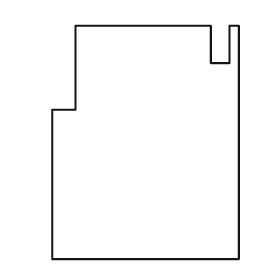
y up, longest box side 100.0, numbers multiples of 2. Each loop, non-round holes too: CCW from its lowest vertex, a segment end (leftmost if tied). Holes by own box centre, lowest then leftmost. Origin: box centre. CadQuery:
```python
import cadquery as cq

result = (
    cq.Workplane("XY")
    .moveTo(-40.0, -50.0)
    .lineTo(40.0, -50.0)
    .lineTo(40.0, 50.0)
    .lineTo(36.0, 50.0)
    .lineTo(36.0, 34.0)
    .lineTo(28.0, 34.0)
    .lineTo(28.0, 50.0)
    .lineTo(-30.0, 50.0)
    .lineTo(-30.0, 14.0)
    .lineTo(-40.0, 14.0)
    .close()
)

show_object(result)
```